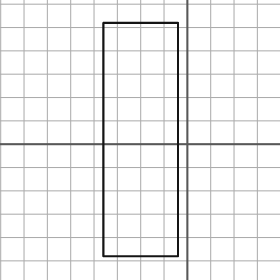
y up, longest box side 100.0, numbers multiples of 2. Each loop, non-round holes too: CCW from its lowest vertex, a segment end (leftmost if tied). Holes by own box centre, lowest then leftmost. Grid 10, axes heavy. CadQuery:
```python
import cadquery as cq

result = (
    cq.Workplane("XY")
    .moveTo(-36.0, -48.0)
    .lineTo(-4.0, -48.0)
    .lineTo(-4.0, 52.0)
    .lineTo(-36.0, 52.0)
    .close()
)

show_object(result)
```